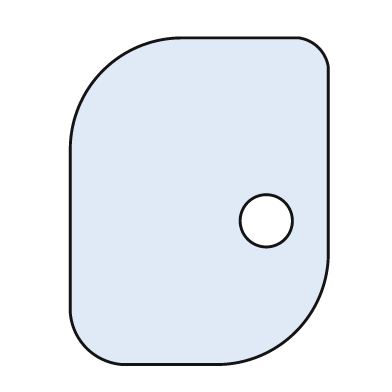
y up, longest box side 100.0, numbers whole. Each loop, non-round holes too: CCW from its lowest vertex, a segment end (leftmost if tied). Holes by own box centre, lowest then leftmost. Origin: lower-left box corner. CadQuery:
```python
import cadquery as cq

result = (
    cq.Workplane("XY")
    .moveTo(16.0, 0.0)
    .lineTo(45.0, 0.0)
    .threePointArc((69.0, 10.0), (79.0, 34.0))
    .lineTo(79.0, 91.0)
    .threePointArc((76.0, 97.0), (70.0, 100.0))
    .lineTo(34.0, 100.0)
    .threePointArc((10.0, 90.0), (0.0, 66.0))
    .lineTo(0.0, 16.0)
    .threePointArc((5.0, 5.0), (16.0, 0.0))
    .close()
    .moveTo(60.0, 44.0)
    .circle(8.0)
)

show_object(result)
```